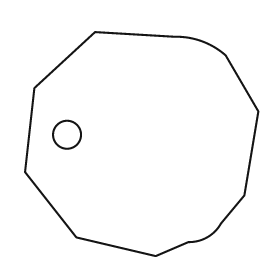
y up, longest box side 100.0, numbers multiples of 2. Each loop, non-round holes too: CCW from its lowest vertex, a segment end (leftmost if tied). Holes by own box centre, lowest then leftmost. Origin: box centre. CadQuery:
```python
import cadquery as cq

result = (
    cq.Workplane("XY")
    .moveTo(6.0, -48.0)
    .lineTo(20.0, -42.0)
    .threePointArc((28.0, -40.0), (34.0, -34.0))
    .lineTo(44.0, -22.0)
    .lineTo(50.0, 14.0)
    .lineTo(36.0, 38.0)
    .threePointArc((26.0, 44.0), (14.0, 46.0))
    .lineTo(-20.0, 48.0)
    .lineTo(-46.0, 24.0)
    .lineTo(-50.0, -12.0)
    .lineTo(-28.0, -40.0)
    .close()
    .moveTo(-32.0, 4.0)
    .circle(6.0)
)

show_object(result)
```